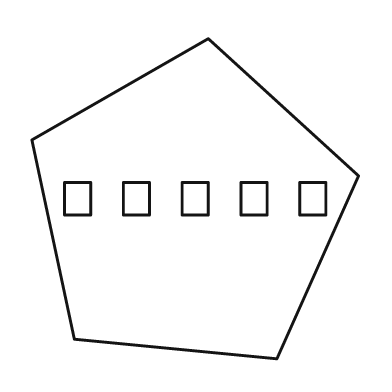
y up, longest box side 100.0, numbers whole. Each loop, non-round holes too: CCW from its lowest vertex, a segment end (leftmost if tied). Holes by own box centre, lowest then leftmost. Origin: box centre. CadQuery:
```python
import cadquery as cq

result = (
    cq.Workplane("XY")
    .moveTo(25.0, -49.0)
    .lineTo(50.0, 7.0)
    .lineTo(4.0, 49.0)
    .lineTo(-50.0, 18.0)
    .lineTo(-37.0, -43.0)
    .close()
    .moveTo(-40.0, -5.0)
    .lineTo(-32.0, -5.0)
    .lineTo(-32.0, 5.0)
    .lineTo(-40.0, 5.0)
    .close()
    .moveTo(-22.0, -5.0)
    .lineTo(-14.0, -5.0)
    .lineTo(-14.0, 5.0)
    .lineTo(-22.0, 5.0)
    .close()
    .moveTo(-4.0, -5.0)
    .lineTo(4.0, -5.0)
    .lineTo(4.0, 5.0)
    .lineTo(-4.0, 5.0)
    .close()
    .moveTo(14.0, -5.0)
    .lineTo(22.0, -5.0)
    .lineTo(22.0, 5.0)
    .lineTo(14.0, 5.0)
    .close()
    .moveTo(32.0, -5.0)
    .lineTo(40.0, -5.0)
    .lineTo(40.0, 5.0)
    .lineTo(32.0, 5.0)
    .close()
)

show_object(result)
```